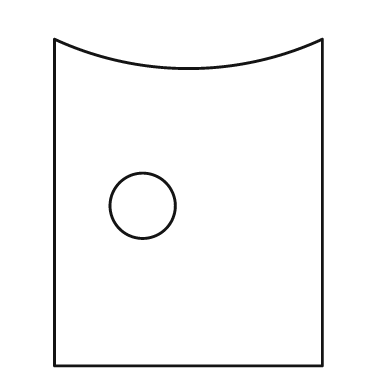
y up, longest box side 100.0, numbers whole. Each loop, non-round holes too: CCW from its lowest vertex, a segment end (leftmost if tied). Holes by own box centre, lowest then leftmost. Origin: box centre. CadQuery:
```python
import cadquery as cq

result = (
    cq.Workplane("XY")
    .moveTo(-41.0, -50.0)
    .lineTo(41.0, -50.0)
    .lineTo(41.0, 50.0)
    .threePointArc((0.0, 41.0), (-41.0, 50.0))
    .close()
    .moveTo(-14.0, -1.0)
    .circle(10.0)
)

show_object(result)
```